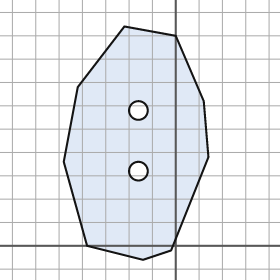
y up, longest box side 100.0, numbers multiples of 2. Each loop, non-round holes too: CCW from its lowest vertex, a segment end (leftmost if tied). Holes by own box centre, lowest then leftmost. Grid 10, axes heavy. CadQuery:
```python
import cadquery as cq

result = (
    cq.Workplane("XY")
    .moveTo(-14.0, -6.0)
    .lineTo(-2.0, -2.0)
    .lineTo(14.0, 38.0)
    .lineTo(12.0, 62.0)
    .lineTo(0.0, 90.0)
    .lineTo(-22.0, 94.0)
    .lineTo(-42.0, 68.0)
    .lineTo(-48.0, 36.0)
    .lineTo(-38.0, 0.0)
    .close()
    .moveTo(-16.0, 32.0)
    .circle(4.0)
    .moveTo(-16.0, 58.0)
    .circle(4.0)
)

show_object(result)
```